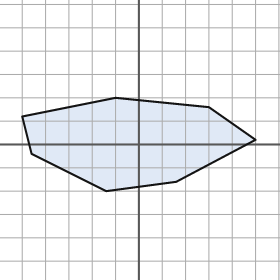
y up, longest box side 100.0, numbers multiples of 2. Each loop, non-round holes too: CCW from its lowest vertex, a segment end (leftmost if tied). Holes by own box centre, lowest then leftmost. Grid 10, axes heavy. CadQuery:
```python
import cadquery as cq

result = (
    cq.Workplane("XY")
    .moveTo(-14.0, -20.0)
    .lineTo(16.0, -16.0)
    .lineTo(50.0, 2.0)
    .lineTo(30.0, 16.0)
    .lineTo(-10.0, 20.0)
    .lineTo(-50.0, 12.0)
    .lineTo(-46.0, -4.0)
    .close()
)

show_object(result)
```